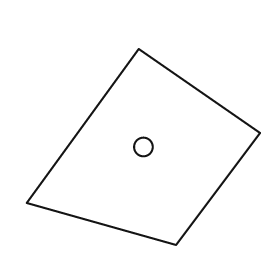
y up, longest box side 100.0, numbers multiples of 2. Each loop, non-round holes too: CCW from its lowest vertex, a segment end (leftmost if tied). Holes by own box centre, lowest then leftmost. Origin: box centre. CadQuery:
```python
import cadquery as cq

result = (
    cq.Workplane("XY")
    .moveTo(14.0, -42.0)
    .lineTo(50.0, 6.0)
    .lineTo(-2.0, 42.0)
    .lineTo(-50.0, -24.0)
    .close()
    .moveTo(0.0, 0.0)
    .circle(4.0)
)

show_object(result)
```